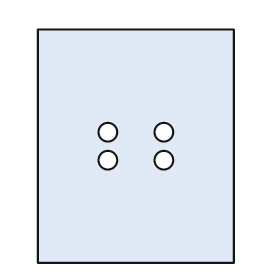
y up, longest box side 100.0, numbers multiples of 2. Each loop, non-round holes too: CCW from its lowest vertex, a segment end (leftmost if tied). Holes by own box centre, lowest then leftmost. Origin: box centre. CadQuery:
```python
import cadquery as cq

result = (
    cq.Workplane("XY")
    .moveTo(-42.0, -50.0)
    .lineTo(42.0, -50.0)
    .lineTo(42.0, 50.0)
    .lineTo(-42.0, 50.0)
    .close()
    .moveTo(-12.0, -6.0)
    .circle(4.0)
    .moveTo(12.0, -6.0)
    .circle(4.0)
    .moveTo(-12.0, 6.0)
    .circle(4.0)
    .moveTo(12.0, 6.0)
    .circle(4.0)
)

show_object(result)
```